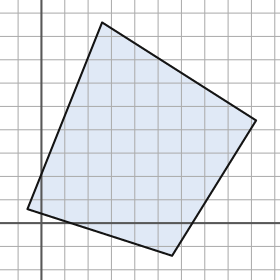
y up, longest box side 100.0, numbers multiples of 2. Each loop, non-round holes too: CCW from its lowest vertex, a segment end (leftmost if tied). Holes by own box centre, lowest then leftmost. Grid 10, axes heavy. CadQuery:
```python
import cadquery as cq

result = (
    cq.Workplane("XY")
    .moveTo(56.0, -14.0)
    .lineTo(92.0, 44.0)
    .lineTo(26.0, 86.0)
    .lineTo(-6.0, 6.0)
    .close()
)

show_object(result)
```